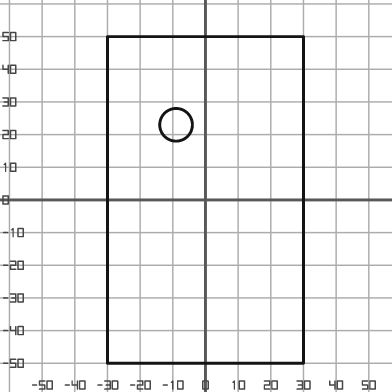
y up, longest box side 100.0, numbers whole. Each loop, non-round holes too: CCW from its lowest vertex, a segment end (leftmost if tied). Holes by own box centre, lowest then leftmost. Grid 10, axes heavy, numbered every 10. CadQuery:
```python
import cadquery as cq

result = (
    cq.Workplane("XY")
    .moveTo(-30.0, -50.0)
    .lineTo(30.0, -50.0)
    .lineTo(30.0, 50.0)
    .lineTo(-30.0, 50.0)
    .close()
    .moveTo(-9.0, 23.0)
    .circle(5.0)
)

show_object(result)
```